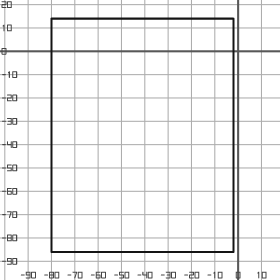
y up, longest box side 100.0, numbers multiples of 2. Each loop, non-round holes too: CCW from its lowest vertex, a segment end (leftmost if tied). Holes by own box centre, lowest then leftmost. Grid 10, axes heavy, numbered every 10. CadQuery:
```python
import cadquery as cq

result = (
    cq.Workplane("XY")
    .moveTo(-80.0, -86.0)
    .lineTo(-2.0, -86.0)
    .lineTo(-2.0, 14.0)
    .lineTo(-80.0, 14.0)
    .close()
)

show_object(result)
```